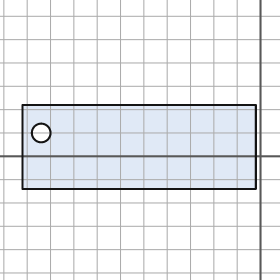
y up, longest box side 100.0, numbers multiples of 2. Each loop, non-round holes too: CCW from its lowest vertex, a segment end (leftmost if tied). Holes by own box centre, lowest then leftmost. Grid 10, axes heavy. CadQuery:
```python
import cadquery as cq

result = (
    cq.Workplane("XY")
    .moveTo(-102.0, -14.0)
    .lineTo(-2.0, -14.0)
    .lineTo(-2.0, 22.0)
    .lineTo(-102.0, 22.0)
    .close()
    .moveTo(-94.0, 10.0)
    .circle(4.0)
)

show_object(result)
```